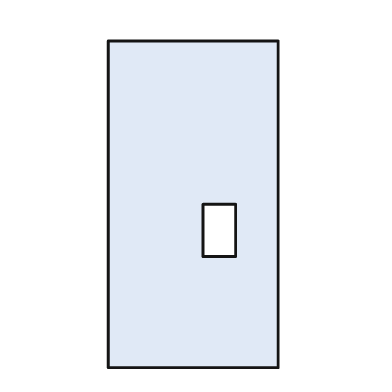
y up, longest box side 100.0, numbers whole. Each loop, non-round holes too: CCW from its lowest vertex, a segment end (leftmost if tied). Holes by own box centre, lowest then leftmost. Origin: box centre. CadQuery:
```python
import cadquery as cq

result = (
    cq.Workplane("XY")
    .moveTo(-26.0, -50.0)
    .lineTo(26.0, -50.0)
    .lineTo(26.0, 50.0)
    .lineTo(-26.0, 50.0)
    .close()
    .moveTo(3.0, -16.0)
    .lineTo(13.0, -16.0)
    .lineTo(13.0, 0.0)
    .lineTo(3.0, 0.0)
    .close()
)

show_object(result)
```